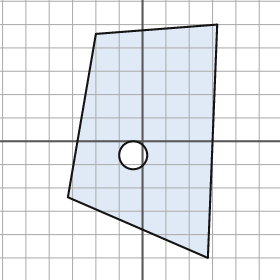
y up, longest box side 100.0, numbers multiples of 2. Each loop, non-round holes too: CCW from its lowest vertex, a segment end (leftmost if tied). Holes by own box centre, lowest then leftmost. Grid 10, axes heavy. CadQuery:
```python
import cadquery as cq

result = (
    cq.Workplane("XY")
    .moveTo(28.0, -50.0)
    .lineTo(32.0, 50.0)
    .lineTo(-20.0, 46.0)
    .lineTo(-32.0, -24.0)
    .close()
    .moveTo(-4.0, -6.0)
    .circle(6.0)
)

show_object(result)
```